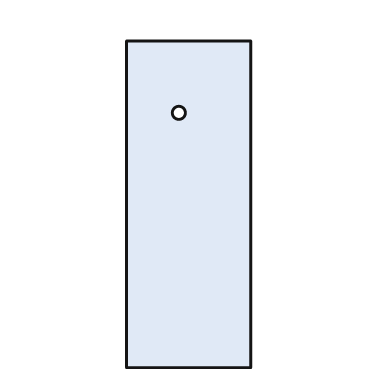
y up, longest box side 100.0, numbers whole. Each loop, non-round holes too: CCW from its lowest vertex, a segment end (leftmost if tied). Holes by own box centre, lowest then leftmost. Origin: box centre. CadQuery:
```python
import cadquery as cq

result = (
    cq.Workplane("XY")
    .moveTo(-19.0, -50.0)
    .lineTo(19.0, -50.0)
    .lineTo(19.0, 50.0)
    .lineTo(-19.0, 50.0)
    .close()
    .moveTo(-3.0, 28.0)
    .circle(2.0)
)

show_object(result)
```